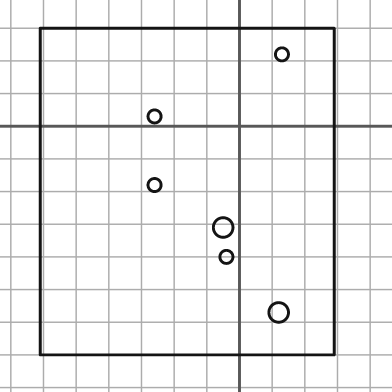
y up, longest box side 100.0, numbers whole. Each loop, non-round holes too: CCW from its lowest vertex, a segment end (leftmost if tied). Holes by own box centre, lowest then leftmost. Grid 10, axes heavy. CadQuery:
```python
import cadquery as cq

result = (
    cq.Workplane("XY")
    .moveTo(-61.0, -70.0)
    .lineTo(29.0, -70.0)
    .lineTo(29.0, 30.0)
    .lineTo(-61.0, 30.0)
    .close()
    .moveTo(12.0, -57.0)
    .circle(3.0)
    .moveTo(-4.0, -40.0)
    .circle(2.0)
    .moveTo(-5.0, -31.0)
    .circle(3.0)
    .moveTo(-26.0, -18.0)
    .circle(2.0)
    .moveTo(-26.0, 3.0)
    .circle(2.0)
    .moveTo(13.0, 22.0)
    .circle(2.0)
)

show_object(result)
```